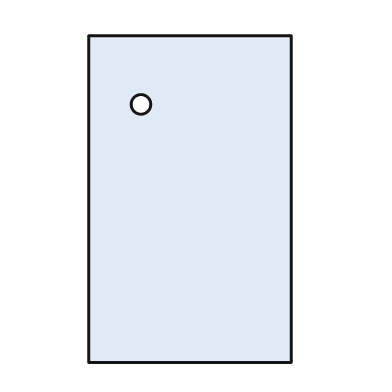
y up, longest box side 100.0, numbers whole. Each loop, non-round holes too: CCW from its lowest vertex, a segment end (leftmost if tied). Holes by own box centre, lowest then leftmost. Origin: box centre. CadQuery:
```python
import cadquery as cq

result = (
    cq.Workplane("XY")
    .moveTo(-31.0, -50.0)
    .lineTo(31.0, -50.0)
    .lineTo(31.0, 50.0)
    .lineTo(-31.0, 50.0)
    .close()
    .moveTo(-15.0, 29.0)
    .circle(3.0)
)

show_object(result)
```